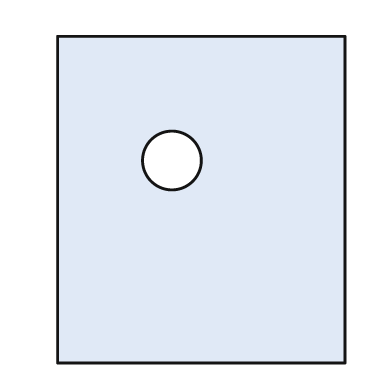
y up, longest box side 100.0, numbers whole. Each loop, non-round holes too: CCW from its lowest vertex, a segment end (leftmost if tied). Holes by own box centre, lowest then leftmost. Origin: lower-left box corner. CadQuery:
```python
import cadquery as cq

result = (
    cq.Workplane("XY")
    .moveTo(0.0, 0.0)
    .lineTo(88.0, 0.0)
    .lineTo(88.0, 100.0)
    .lineTo(0.0, 100.0)
    .close()
    .moveTo(35.0, 62.0)
    .circle(9.0)
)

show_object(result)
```